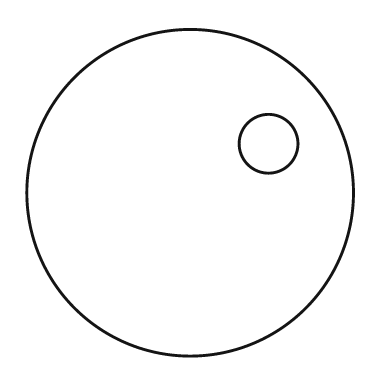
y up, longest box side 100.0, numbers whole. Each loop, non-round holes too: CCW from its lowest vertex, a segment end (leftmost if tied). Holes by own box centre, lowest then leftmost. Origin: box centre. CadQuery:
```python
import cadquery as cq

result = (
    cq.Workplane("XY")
    .moveTo(0.0, 0.0)
    .circle(50.0)
    .moveTo(24.0, 15.0)
    .circle(9.0)
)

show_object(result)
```